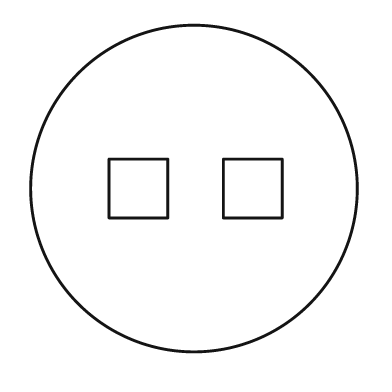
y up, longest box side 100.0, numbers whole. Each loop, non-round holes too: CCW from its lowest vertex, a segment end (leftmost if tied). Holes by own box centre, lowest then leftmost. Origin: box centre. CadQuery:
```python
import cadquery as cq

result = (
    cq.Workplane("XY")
    .moveTo(0.0, 0.0)
    .circle(50.0)
    .moveTo(-26.0, -9.0)
    .lineTo(-8.0, -9.0)
    .lineTo(-8.0, 9.0)
    .lineTo(-26.0, 9.0)
    .close()
    .moveTo(9.0, -9.0)
    .lineTo(27.0, -9.0)
    .lineTo(27.0, 9.0)
    .lineTo(9.0, 9.0)
    .close()
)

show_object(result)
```